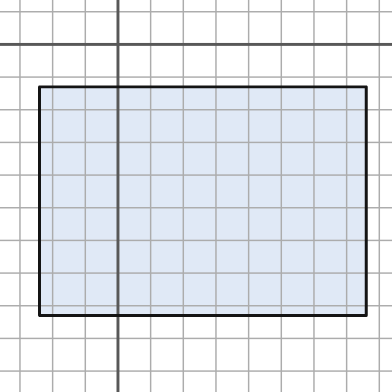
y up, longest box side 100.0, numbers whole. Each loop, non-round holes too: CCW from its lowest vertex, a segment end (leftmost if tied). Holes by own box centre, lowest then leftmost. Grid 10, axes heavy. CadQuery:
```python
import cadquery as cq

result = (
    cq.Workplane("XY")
    .moveTo(-24.0, -83.0)
    .lineTo(76.0, -83.0)
    .lineTo(76.0, -13.0)
    .lineTo(-24.0, -13.0)
    .close()
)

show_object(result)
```